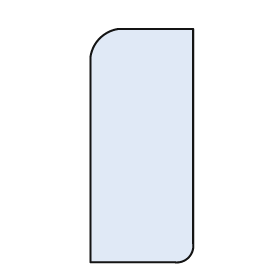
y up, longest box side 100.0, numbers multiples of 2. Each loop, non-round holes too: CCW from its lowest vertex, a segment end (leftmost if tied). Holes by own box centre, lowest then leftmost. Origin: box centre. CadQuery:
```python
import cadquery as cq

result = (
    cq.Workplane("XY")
    .moveTo(-22.0, -50.0)
    .lineTo(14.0, -50.0)
    .threePointArc((20.0, -48.0), (22.0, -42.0))
    .lineTo(22.0, 50.0)
    .lineTo(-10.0, 50.0)
    .threePointArc((-18.0, 46.0), (-22.0, 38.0))
    .close()
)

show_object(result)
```